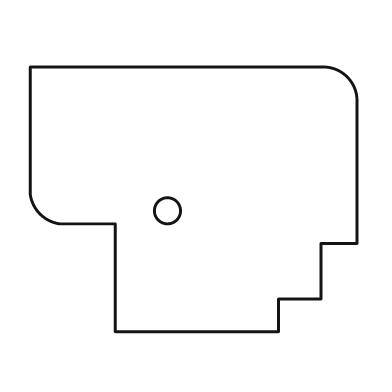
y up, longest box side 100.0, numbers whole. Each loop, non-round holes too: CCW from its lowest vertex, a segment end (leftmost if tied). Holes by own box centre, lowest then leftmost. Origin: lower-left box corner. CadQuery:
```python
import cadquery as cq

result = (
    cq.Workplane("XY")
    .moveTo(26.0, 0.0)
    .lineTo(76.0, 0.0)
    .lineTo(76.0, 10.0)
    .lineTo(89.0, 10.0)
    .lineTo(89.0, 27.0)
    .lineTo(100.0, 27.0)
    .lineTo(100.0, 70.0)
    .threePointArc((97.0, 78.0), (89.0, 81.0))
    .lineTo(0.0, 81.0)
    .lineTo(0.0, 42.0)
    .threePointArc((3.0, 36.0), (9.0, 33.0))
    .lineTo(26.0, 33.0)
    .close()
    .moveTo(42.0, 37.0)
    .circle(4.0)
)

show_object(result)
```